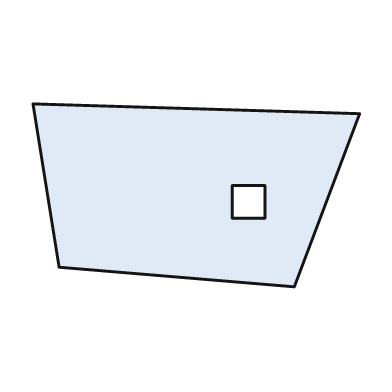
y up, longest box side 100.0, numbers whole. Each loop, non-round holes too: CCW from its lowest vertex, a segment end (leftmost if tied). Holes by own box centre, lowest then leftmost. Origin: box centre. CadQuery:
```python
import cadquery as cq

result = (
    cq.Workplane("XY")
    .moveTo(30.0, -28.0)
    .lineTo(50.0, 25.0)
    .lineTo(-50.0, 28.0)
    .lineTo(-42.0, -22.0)
    .close()
    .moveTo(11.0, -7.0)
    .lineTo(21.0, -7.0)
    .lineTo(21.0, 3.0)
    .lineTo(11.0, 3.0)
    .close()
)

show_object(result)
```